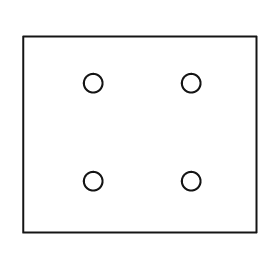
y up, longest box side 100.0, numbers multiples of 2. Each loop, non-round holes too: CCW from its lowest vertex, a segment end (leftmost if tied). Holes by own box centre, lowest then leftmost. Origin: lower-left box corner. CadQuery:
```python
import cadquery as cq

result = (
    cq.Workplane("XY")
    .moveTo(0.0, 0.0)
    .lineTo(100.0, 0.0)
    .lineTo(100.0, 84.0)
    .lineTo(0.0, 84.0)
    .close()
    .moveTo(30.0, 22.0)
    .circle(4.0)
    .moveTo(72.0, 22.0)
    .circle(4.0)
    .moveTo(30.0, 64.0)
    .circle(4.0)
    .moveTo(72.0, 64.0)
    .circle(4.0)
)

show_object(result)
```